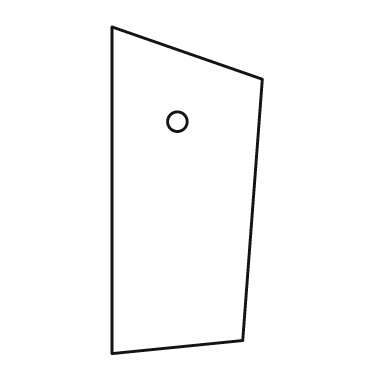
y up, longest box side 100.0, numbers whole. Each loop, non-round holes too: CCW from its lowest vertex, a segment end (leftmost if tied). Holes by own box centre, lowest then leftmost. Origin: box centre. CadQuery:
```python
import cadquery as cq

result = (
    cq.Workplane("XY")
    .moveTo(-23.0, -50.0)
    .lineTo(17.0, -46.0)
    .lineTo(23.0, 34.0)
    .lineTo(-23.0, 50.0)
    .close()
    .moveTo(-3.0, 21.0)
    .circle(3.0)
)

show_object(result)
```